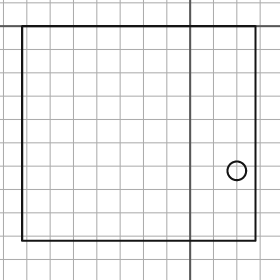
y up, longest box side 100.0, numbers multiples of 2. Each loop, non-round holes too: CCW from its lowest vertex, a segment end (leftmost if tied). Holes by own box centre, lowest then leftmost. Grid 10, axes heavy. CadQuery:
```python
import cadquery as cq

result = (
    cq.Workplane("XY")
    .moveTo(-72.0, -92.0)
    .lineTo(28.0, -92.0)
    .lineTo(28.0, 0.0)
    .lineTo(-72.0, 0.0)
    .close()
    .moveTo(20.0, -62.0)
    .circle(4.0)
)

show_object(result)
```